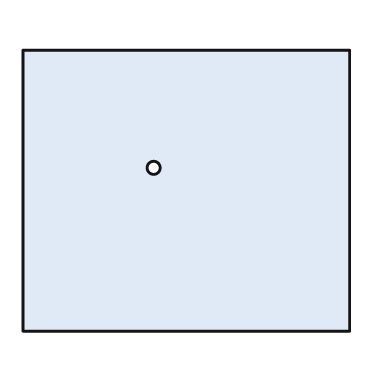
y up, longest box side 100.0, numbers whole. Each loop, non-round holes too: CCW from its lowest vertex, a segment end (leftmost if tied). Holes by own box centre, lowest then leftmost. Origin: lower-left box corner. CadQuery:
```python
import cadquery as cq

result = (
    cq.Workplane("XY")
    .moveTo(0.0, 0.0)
    .lineTo(100.0, 0.0)
    .lineTo(100.0, 86.0)
    .lineTo(0.0, 86.0)
    .close()
    .moveTo(40.0, 50.0)
    .circle(2.0)
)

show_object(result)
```